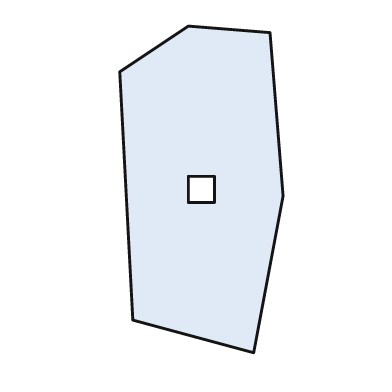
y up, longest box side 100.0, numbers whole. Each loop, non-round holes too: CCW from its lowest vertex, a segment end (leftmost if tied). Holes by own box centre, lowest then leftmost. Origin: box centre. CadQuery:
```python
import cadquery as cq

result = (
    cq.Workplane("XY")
    .moveTo(16.0, -50.0)
    .lineTo(25.0, -2.0)
    .lineTo(21.0, 48.0)
    .lineTo(-4.0, 50.0)
    .lineTo(-25.0, 36.0)
    .lineTo(-21.0, -40.0)
    .close()
    .moveTo(-4.0, -4.0)
    .lineTo(4.0, -4.0)
    .lineTo(4.0, 4.0)
    .lineTo(-4.0, 4.0)
    .close()
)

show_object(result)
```